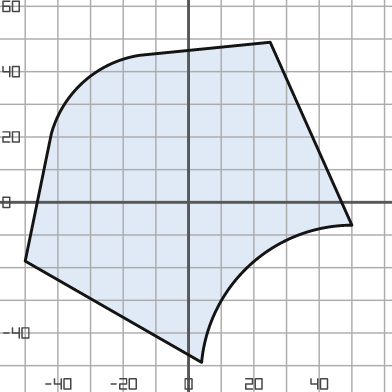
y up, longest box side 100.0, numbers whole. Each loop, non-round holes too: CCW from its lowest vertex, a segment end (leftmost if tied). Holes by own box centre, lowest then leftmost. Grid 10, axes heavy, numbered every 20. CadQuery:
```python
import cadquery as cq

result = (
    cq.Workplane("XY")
    .moveTo(4.0, -49.0)
    .threePointArc((19.0, -19.0), (50.0, -7.0))
    .lineTo(25.0, 49.0)
    .lineTo(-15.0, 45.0)
    .threePointArc((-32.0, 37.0), (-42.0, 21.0))
    .lineTo(-50.0, -18.0)
    .close()
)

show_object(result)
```